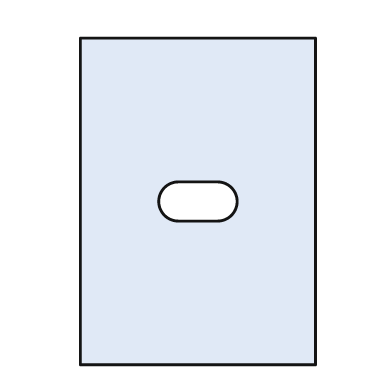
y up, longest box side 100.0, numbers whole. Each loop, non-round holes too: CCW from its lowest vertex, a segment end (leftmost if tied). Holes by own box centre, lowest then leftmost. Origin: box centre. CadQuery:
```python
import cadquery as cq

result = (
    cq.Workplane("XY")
    .moveTo(-36.0, -50.0)
    .lineTo(36.0, -50.0)
    .lineTo(36.0, 50.0)
    .lineTo(-36.0, 50.0)
    .close()
    .moveTo(-6.0, -6.0)
    .lineTo(6.0, -6.0)
    .threePointArc((12.0, 0.0), (6.0, 6.0))
    .lineTo(-6.0, 6.0)
    .threePointArc((-12.0, 0.0), (-6.0, -6.0))
    .close()
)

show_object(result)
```